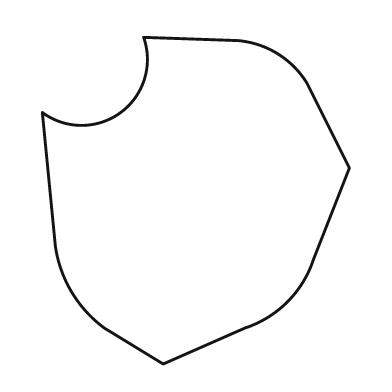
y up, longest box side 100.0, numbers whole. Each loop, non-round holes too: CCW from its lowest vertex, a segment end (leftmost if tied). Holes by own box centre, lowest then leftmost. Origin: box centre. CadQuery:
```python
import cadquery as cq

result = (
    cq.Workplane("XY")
    .moveTo(-10.0, -50.0)
    .lineTo(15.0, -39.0)
    .threePointArc((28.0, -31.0), (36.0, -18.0))
    .lineTo(47.0, 10.0)
    .lineTo(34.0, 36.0)
    .threePointArc((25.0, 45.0), (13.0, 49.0))
    .lineTo(-16.0, 50.0)
    .threePointArc((-23.0, 27.0), (-47.0, 27.0))
    .lineTo(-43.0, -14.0)
    .threePointArc((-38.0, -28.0), (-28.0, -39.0))
    .close()
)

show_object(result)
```